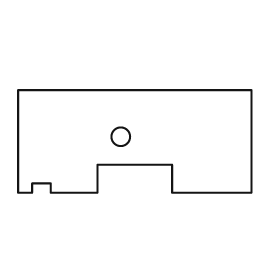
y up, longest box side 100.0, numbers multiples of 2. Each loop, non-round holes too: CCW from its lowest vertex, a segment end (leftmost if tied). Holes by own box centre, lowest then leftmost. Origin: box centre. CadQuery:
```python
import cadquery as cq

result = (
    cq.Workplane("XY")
    .moveTo(-50.0, -22.0)
    .lineTo(-44.0, -22.0)
    .lineTo(-44.0, -18.0)
    .lineTo(-36.0, -18.0)
    .lineTo(-36.0, -22.0)
    .lineTo(-16.0, -22.0)
    .lineTo(-16.0, -10.0)
    .lineTo(16.0, -10.0)
    .lineTo(16.0, -22.0)
    .lineTo(50.0, -22.0)
    .lineTo(50.0, 22.0)
    .lineTo(-50.0, 22.0)
    .close()
    .moveTo(-6.0, 2.0)
    .circle(4.0)
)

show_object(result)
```